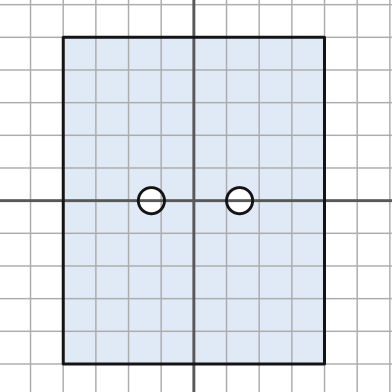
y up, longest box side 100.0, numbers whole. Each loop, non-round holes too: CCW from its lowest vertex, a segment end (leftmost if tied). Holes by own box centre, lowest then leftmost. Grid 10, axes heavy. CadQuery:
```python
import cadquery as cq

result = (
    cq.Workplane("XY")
    .moveTo(-40.0, -50.0)
    .lineTo(40.0, -50.0)
    .lineTo(40.0, 50.0)
    .lineTo(-40.0, 50.0)
    .close()
    .moveTo(-13.0, 0.0)
    .circle(4.0)
    .moveTo(14.0, 0.0)
    .circle(4.0)
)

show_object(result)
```